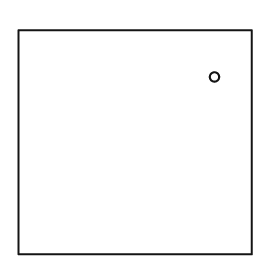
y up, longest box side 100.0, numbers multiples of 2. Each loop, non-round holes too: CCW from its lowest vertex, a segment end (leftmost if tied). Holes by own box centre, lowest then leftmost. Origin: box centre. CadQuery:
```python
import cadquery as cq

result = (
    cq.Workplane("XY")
    .moveTo(-50.0, -48.0)
    .lineTo(50.0, -48.0)
    .lineTo(50.0, 48.0)
    .lineTo(-50.0, 48.0)
    .close()
    .moveTo(34.0, 28.0)
    .circle(2.0)
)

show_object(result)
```